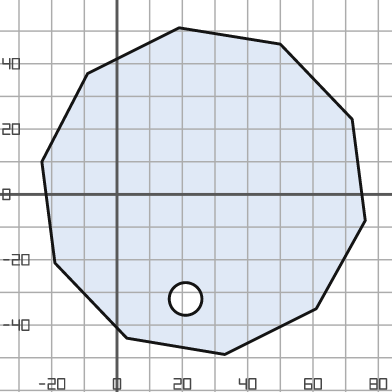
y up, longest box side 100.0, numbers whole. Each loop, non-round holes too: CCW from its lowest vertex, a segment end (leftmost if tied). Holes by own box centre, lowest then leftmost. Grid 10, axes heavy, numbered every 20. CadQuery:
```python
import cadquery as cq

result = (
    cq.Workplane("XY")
    .moveTo(33.0, -49.0)
    .lineTo(61.0, -35.0)
    .lineTo(76.0, -8.0)
    .lineTo(72.0, 23.0)
    .lineTo(50.0, 46.0)
    .lineTo(19.0, 51.0)
    .lineTo(-9.0, 37.0)
    .lineTo(-23.0, 10.0)
    .lineTo(-19.0, -21.0)
    .lineTo(3.0, -44.0)
    .close()
    .moveTo(21.0, -32.0)
    .circle(5.0)
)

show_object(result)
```